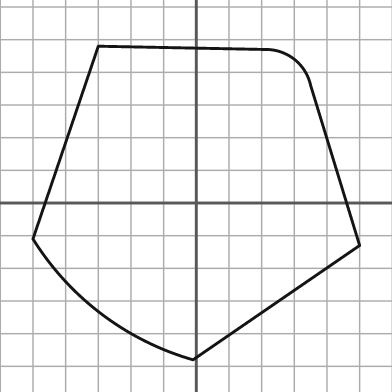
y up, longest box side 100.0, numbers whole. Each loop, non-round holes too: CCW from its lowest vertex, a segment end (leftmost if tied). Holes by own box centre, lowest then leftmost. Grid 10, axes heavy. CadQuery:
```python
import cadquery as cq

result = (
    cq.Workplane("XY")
    .moveTo(-1.0, -48.0)
    .lineTo(50.0, -13.0)
    .lineTo(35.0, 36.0)
    .threePointArc((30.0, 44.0), (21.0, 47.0))
    .lineTo(-30.0, 48.0)
    .lineTo(-50.0, -11.0)
    .threePointArc((-29.0, -34.0), (-1.0, -48.0))
    .close()
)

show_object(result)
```